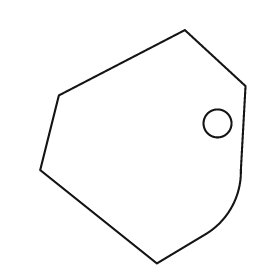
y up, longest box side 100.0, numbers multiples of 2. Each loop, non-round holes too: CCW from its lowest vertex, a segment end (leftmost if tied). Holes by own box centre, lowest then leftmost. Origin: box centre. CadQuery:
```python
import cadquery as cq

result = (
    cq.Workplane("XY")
    .moveTo(6.0, -50.0)
    .lineTo(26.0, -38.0)
    .threePointArc((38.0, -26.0), (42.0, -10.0))
    .lineTo(44.0, 26.0)
    .lineTo(18.0, 50.0)
    .lineTo(-36.0, 22.0)
    .lineTo(-44.0, -10.0)
    .close()
    .moveTo(32.0, 10.0)
    .circle(6.0)
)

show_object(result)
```